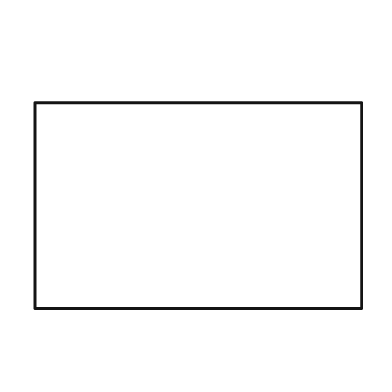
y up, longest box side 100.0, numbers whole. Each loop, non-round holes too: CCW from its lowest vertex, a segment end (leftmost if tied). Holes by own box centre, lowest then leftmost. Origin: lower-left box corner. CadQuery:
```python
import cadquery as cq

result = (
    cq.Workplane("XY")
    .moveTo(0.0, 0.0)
    .lineTo(100.0, 0.0)
    .lineTo(100.0, 63.0)
    .lineTo(0.0, 63.0)
    .close()
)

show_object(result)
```